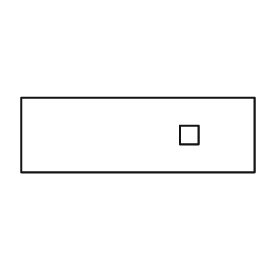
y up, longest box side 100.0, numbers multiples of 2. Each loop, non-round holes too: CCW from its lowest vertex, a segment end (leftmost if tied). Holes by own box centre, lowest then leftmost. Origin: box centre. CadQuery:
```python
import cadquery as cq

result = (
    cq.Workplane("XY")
    .moveTo(-50.0, -16.0)
    .lineTo(50.0, -16.0)
    .lineTo(50.0, 16.0)
    .lineTo(-50.0, 16.0)
    .close()
    .moveTo(18.0, -4.0)
    .lineTo(26.0, -4.0)
    .lineTo(26.0, 4.0)
    .lineTo(18.0, 4.0)
    .close()
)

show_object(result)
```